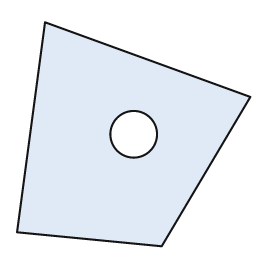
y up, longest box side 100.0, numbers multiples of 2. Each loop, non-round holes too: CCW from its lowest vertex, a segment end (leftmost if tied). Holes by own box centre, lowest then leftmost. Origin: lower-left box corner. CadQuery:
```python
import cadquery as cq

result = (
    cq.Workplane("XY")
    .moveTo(62.0, 0.0)
    .lineTo(100.0, 64.0)
    .lineTo(12.0, 96.0)
    .lineTo(0.0, 6.0)
    .close()
    .moveTo(50.0, 48.0)
    .circle(10.0)
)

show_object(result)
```